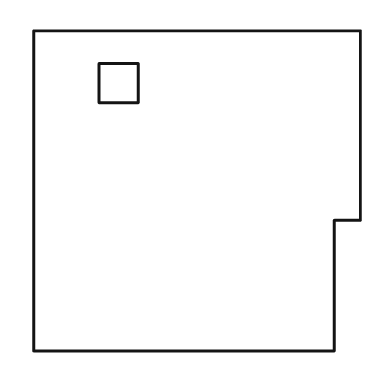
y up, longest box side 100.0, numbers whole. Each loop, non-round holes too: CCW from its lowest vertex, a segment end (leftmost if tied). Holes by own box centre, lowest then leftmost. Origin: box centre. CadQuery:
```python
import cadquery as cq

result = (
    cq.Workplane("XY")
    .moveTo(-50.0, -49.0)
    .lineTo(42.0, -49.0)
    .lineTo(42.0, -9.0)
    .lineTo(50.0, -9.0)
    .lineTo(50.0, 49.0)
    .lineTo(-50.0, 49.0)
    .close()
    .moveTo(-30.0, 27.0)
    .lineTo(-18.0, 27.0)
    .lineTo(-18.0, 39.0)
    .lineTo(-30.0, 39.0)
    .close()
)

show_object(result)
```